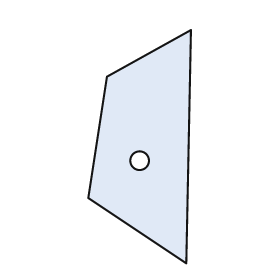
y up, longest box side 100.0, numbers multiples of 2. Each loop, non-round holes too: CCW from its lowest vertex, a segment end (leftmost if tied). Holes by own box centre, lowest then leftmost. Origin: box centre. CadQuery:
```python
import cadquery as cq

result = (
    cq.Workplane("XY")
    .moveTo(20.0, -50.0)
    .lineTo(22.0, 50.0)
    .lineTo(-14.0, 30.0)
    .lineTo(-22.0, -22.0)
    .close()
    .moveTo(0.0, -6.0)
    .circle(4.0)
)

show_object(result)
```